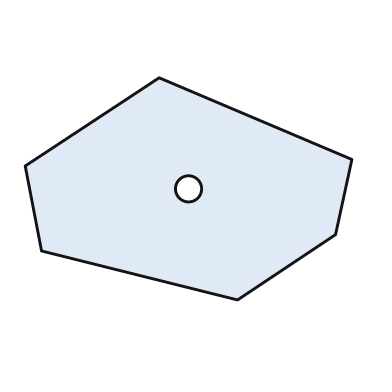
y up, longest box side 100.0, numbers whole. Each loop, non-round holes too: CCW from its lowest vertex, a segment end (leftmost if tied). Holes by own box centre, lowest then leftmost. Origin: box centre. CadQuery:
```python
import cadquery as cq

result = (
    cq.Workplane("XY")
    .moveTo(15.0, -34.0)
    .lineTo(45.0, -14.0)
    .lineTo(50.0, 9.0)
    .lineTo(-9.0, 34.0)
    .lineTo(-50.0, 7.0)
    .lineTo(-45.0, -19.0)
    .close()
    .moveTo(0.0, 0.0)
    .circle(4.0)
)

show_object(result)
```